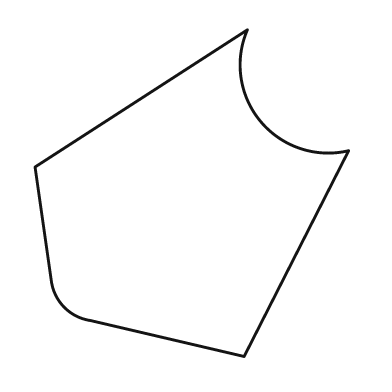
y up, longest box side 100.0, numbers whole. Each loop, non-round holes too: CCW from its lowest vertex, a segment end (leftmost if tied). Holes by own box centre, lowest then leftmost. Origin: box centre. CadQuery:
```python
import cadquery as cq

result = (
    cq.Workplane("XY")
    .moveTo(16.0, -50.0)
    .lineTo(48.0, 13.0)
    .threePointArc((21.0, 22.0), (17.0, 50.0))
    .lineTo(-48.0, 8.0)
    .lineTo(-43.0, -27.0)
    .threePointArc((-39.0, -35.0), (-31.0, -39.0))
    .close()
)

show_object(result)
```